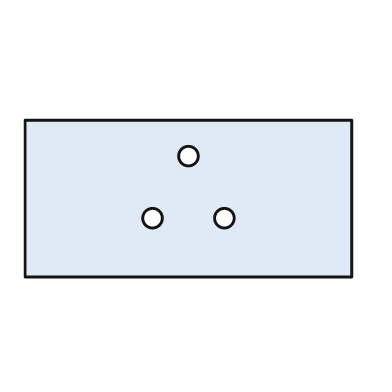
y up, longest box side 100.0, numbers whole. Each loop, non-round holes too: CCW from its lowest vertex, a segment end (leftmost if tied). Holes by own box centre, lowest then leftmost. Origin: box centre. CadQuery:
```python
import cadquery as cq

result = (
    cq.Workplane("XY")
    .moveTo(-50.0, -24.0)
    .lineTo(50.0, -24.0)
    .lineTo(50.0, 24.0)
    .lineTo(-50.0, 24.0)
    .close()
    .moveTo(-11.0, -6.0)
    .circle(3.0)
    .moveTo(11.0, -6.0)
    .circle(3.0)
    .moveTo(0.0, 13.0)
    .circle(3.0)
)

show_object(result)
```